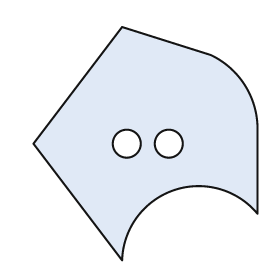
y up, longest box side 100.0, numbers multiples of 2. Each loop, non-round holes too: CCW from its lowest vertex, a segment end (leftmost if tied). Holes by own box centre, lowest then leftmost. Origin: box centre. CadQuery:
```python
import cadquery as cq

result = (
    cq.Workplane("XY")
    .moveTo(-10.0, -50.0)
    .threePointArc((12.0, -20.0), (48.0, -30.0))
    .lineTo(48.0, 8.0)
    .threePointArc((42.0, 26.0), (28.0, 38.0))
    .lineTo(-10.0, 50.0)
    .lineTo(-48.0, 0.0)
    .close()
    .moveTo(-8.0, 0.0)
    .circle(6.0)
    .moveTo(10.0, 0.0)
    .circle(6.0)
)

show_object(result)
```